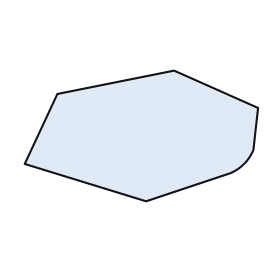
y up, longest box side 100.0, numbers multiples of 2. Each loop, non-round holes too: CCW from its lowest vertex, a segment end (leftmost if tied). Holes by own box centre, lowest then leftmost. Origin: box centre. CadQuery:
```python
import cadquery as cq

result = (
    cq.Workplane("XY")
    .moveTo(2.0, -28.0)
    .lineTo(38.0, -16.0)
    .threePointArc((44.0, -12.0), (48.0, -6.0))
    .lineTo(50.0, 12.0)
    .lineTo(14.0, 28.0)
    .lineTo(-36.0, 18.0)
    .lineTo(-50.0, -12.0)
    .close()
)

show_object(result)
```